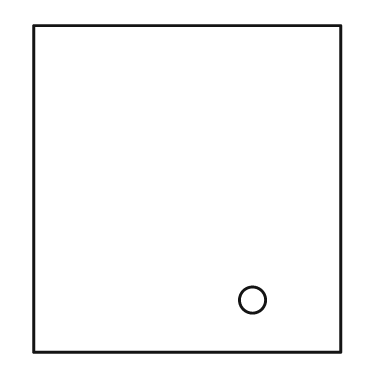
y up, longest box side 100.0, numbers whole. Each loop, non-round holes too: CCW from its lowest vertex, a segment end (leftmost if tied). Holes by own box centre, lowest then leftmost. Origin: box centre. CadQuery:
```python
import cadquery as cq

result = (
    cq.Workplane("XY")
    .moveTo(-47.0, -50.0)
    .lineTo(47.0, -50.0)
    .lineTo(47.0, 50.0)
    .lineTo(-47.0, 50.0)
    .close()
    .moveTo(20.0, -34.0)
    .circle(4.0)
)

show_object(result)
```